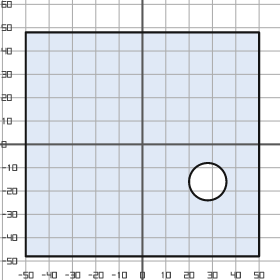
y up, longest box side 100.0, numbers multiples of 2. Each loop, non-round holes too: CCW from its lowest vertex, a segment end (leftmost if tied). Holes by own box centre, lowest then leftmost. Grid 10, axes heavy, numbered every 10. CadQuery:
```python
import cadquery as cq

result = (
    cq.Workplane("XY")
    .moveTo(-50.0, -48.0)
    .lineTo(50.0, -48.0)
    .lineTo(50.0, 48.0)
    .lineTo(-50.0, 48.0)
    .close()
    .moveTo(28.0, -16.0)
    .circle(8.0)
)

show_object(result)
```